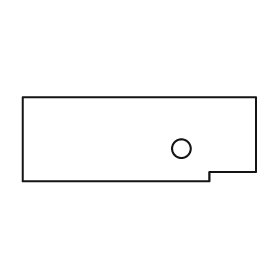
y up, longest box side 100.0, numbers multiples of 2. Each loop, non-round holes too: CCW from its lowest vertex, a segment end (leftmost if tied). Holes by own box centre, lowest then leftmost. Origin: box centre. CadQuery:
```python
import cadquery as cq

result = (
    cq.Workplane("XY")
    .moveTo(-50.0, -18.0)
    .lineTo(30.0, -18.0)
    .lineTo(30.0, -14.0)
    .lineTo(50.0, -14.0)
    .lineTo(50.0, 18.0)
    .lineTo(-50.0, 18.0)
    .close()
    .moveTo(18.0, -4.0)
    .circle(4.0)
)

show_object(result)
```